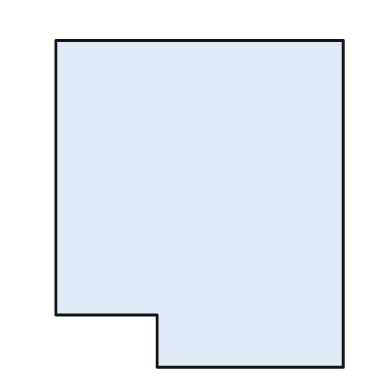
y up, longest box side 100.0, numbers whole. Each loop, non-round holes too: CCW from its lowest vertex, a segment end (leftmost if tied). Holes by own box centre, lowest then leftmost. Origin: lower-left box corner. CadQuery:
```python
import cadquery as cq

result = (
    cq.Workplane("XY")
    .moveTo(31.0, 0.0)
    .lineTo(88.0, 0.0)
    .lineTo(88.0, 100.0)
    .lineTo(0.0, 100.0)
    .lineTo(0.0, 16.0)
    .lineTo(31.0, 16.0)
    .close()
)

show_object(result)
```